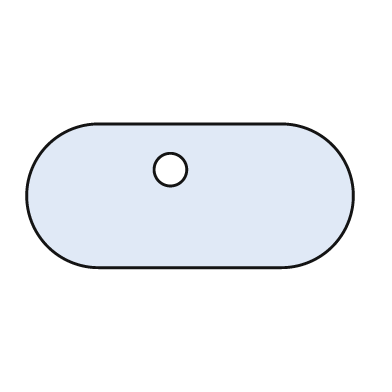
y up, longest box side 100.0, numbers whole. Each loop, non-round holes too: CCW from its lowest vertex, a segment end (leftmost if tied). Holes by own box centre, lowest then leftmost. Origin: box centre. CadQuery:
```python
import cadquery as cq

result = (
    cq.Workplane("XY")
    .moveTo(-28.0, -22.0)
    .lineTo(28.0, -22.0)
    .threePointArc((50.0, 0.0), (28.0, 22.0))
    .lineTo(-28.0, 22.0)
    .threePointArc((-50.0, 0.0), (-28.0, -22.0))
    .close()
    .moveTo(-6.0, 8.0)
    .circle(5.0)
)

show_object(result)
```